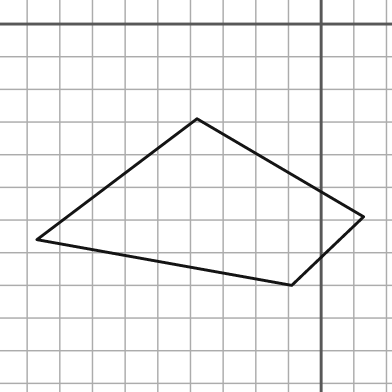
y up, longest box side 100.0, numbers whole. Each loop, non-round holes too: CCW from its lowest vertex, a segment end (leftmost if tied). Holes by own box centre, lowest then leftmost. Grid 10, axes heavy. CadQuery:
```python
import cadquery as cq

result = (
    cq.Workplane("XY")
    .moveTo(-9.0, -80.0)
    .lineTo(13.0, -59.0)
    .lineTo(-38.0, -29.0)
    .lineTo(-87.0, -66.0)
    .close()
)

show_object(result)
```